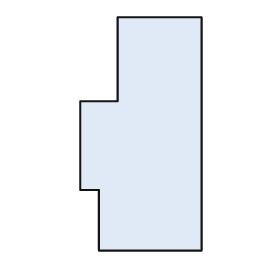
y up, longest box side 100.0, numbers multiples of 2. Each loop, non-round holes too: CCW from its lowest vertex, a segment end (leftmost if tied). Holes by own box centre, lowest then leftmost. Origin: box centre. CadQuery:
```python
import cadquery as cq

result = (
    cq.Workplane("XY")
    .moveTo(-18.0, -50.0)
    .lineTo(26.0, -50.0)
    .lineTo(26.0, 50.0)
    .lineTo(-10.0, 50.0)
    .lineTo(-10.0, 14.0)
    .lineTo(-26.0, 14.0)
    .lineTo(-26.0, -24.0)
    .lineTo(-18.0, -24.0)
    .close()
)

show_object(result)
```